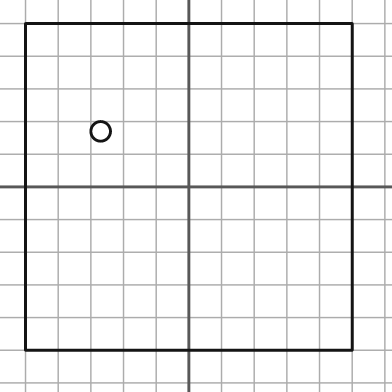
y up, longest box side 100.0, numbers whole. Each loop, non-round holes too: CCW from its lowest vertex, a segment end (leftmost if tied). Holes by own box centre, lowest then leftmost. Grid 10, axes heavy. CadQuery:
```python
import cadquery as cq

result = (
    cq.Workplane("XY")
    .moveTo(-50.0, -50.0)
    .lineTo(50.0, -50.0)
    .lineTo(50.0, 50.0)
    .lineTo(-50.0, 50.0)
    .close()
    .moveTo(-27.0, 17.0)
    .circle(3.0)
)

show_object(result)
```